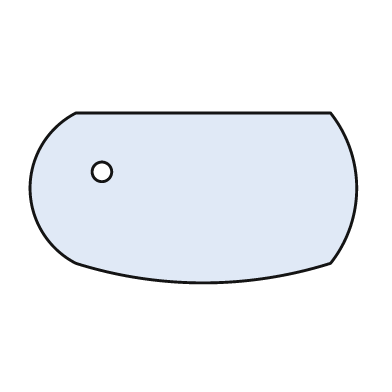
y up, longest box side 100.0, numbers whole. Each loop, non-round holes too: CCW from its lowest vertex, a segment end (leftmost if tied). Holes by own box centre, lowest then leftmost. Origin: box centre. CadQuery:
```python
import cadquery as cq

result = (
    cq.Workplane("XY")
    .moveTo(-36.0, -20.0)
    .threePointArc((3.0, -26.0), (42.0, -20.0))
    .threePointArc((50.0, 3.0), (42.0, 26.0))
    .lineTo(-36.0, 26.0)
    .threePointArc((-50.0, 3.0), (-36.0, -20.0))
    .close()
    .moveTo(-28.0, 8.0)
    .circle(3.0)
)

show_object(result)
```